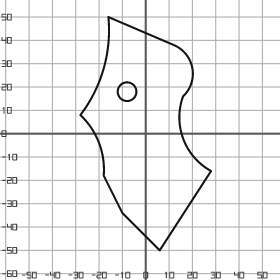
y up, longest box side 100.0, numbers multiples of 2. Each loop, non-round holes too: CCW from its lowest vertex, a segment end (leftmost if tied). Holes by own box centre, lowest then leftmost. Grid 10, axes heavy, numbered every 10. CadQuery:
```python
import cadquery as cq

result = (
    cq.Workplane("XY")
    .moveTo(6.0, -50.0)
    .lineTo(28.0, -16.0)
    .threePointArc((16.0, -2.0), (16.0, 16.0))
    .threePointArc((20.0, 28.0), (12.0, 38.0))
    .lineTo(-16.0, 50.0)
    .threePointArc((-18.0, 28.0), (-28.0, 8.0))
    .threePointArc((-20.0, -4.0), (-18.0, -18.0))
    .lineTo(-10.0, -34.0)
    .close()
    .moveTo(-8.0, 18.0)
    .circle(4.0)
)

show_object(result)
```